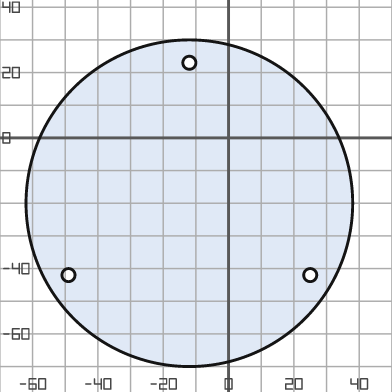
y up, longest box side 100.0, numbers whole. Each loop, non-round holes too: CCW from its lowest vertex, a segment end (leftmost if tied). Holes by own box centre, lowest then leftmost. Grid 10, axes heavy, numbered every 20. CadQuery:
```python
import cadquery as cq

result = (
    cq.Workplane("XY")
    .moveTo(-12.0, -20.0)
    .circle(50.0)
    .moveTo(-49.0, -42.0)
    .circle(2.0)
    .moveTo(25.0, -42.0)
    .circle(2.0)
    .moveTo(-12.0, 23.0)
    .circle(2.0)
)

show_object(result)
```